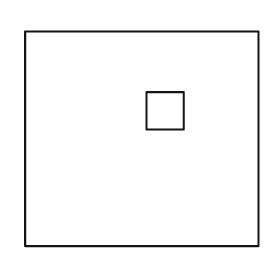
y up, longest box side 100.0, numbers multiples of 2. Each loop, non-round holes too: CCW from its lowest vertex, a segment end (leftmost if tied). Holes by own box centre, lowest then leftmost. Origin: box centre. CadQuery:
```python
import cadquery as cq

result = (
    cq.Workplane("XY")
    .moveTo(-50.0, -46.0)
    .lineTo(50.0, -46.0)
    .lineTo(50.0, 46.0)
    .lineTo(-50.0, 46.0)
    .close()
    .moveTo(2.0, 4.0)
    .lineTo(18.0, 4.0)
    .lineTo(18.0, 20.0)
    .lineTo(2.0, 20.0)
    .close()
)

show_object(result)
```